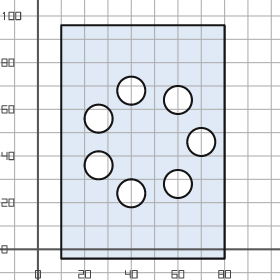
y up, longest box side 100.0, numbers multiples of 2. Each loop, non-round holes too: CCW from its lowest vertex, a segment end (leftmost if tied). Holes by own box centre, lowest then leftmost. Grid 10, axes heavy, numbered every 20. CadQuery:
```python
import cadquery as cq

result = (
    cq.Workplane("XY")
    .moveTo(10.0, -4.0)
    .lineTo(80.0, -4.0)
    .lineTo(80.0, 96.0)
    .lineTo(10.0, 96.0)
    .close()
    .moveTo(40.0, 24.0)
    .circle(6.0)
    .moveTo(60.0, 28.0)
    .circle(6.0)
    .moveTo(26.0, 36.0)
    .circle(6.0)
    .moveTo(70.0, 46.0)
    .circle(6.0)
    .moveTo(26.0, 56.0)
    .circle(6.0)
    .moveTo(60.0, 64.0)
    .circle(6.0)
    .moveTo(40.0, 68.0)
    .circle(6.0)
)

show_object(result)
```